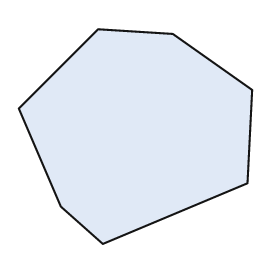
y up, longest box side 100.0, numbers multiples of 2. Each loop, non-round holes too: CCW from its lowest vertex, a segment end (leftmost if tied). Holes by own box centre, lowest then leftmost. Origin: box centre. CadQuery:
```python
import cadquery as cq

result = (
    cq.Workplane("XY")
    .moveTo(-14.0, -46.0)
    .lineTo(48.0, -20.0)
    .lineTo(50.0, 20.0)
    .lineTo(16.0, 44.0)
    .lineTo(-16.0, 46.0)
    .lineTo(-50.0, 12.0)
    .lineTo(-32.0, -30.0)
    .close()
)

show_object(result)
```